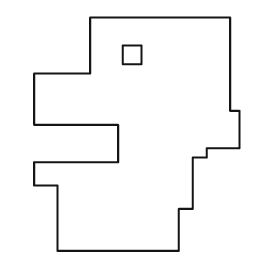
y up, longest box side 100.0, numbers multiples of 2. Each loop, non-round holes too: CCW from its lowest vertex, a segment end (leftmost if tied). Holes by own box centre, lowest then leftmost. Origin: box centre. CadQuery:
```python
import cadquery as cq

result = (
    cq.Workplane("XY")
    .moveTo(-34.0, -50.0)
    .lineTo(18.0, -50.0)
    .lineTo(18.0, -32.0)
    .lineTo(24.0, -32.0)
    .lineTo(24.0, -10.0)
    .lineTo(30.0, -10.0)
    .lineTo(30.0, -6.0)
    .lineTo(44.0, -6.0)
    .lineTo(44.0, 10.0)
    .lineTo(40.0, 10.0)
    .lineTo(40.0, 50.0)
    .lineTo(-20.0, 50.0)
    .lineTo(-20.0, 26.0)
    .lineTo(-44.0, 26.0)
    .lineTo(-44.0, 4.0)
    .lineTo(-8.0, 4.0)
    .lineTo(-8.0, -12.0)
    .lineTo(-44.0, -12.0)
    .lineTo(-44.0, -22.0)
    .lineTo(-34.0, -22.0)
    .close()
    .moveTo(-6.0, 30.0)
    .lineTo(2.0, 30.0)
    .lineTo(2.0, 38.0)
    .lineTo(-6.0, 38.0)
    .close()
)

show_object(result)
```